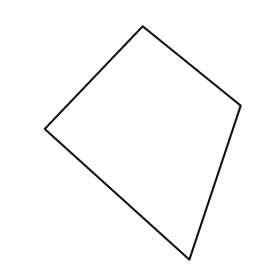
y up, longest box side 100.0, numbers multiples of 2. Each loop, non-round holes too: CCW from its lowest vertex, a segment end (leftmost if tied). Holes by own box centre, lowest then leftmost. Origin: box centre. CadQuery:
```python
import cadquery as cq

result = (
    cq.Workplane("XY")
    .moveTo(20.0, -50.0)
    .lineTo(42.0, 16.0)
    .lineTo(0.0, 50.0)
    .lineTo(-42.0, 6.0)
    .close()
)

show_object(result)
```